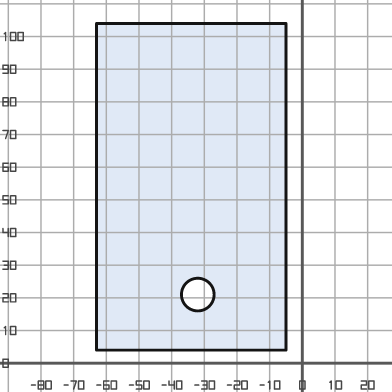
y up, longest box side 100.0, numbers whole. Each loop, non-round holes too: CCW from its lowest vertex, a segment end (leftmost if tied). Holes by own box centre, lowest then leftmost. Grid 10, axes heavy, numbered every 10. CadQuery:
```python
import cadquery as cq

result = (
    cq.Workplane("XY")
    .moveTo(-63.0, 4.0)
    .lineTo(-5.0, 4.0)
    .lineTo(-5.0, 104.0)
    .lineTo(-63.0, 104.0)
    .close()
    .moveTo(-32.0, 21.0)
    .circle(5.0)
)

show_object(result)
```